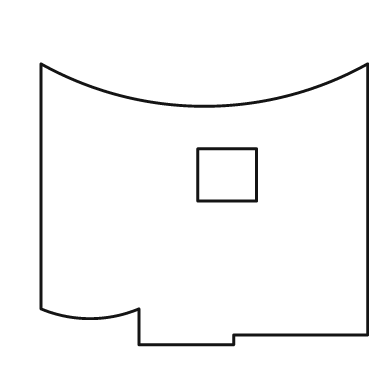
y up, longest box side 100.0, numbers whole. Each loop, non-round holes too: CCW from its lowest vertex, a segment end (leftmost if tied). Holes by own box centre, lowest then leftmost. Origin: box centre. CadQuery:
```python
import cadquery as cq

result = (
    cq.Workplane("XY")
    .moveTo(-20.0, -43.0)
    .lineTo(9.0, -43.0)
    .lineTo(9.0, -40.0)
    .lineTo(50.0, -40.0)
    .lineTo(50.0, 43.0)
    .threePointArc((0.0, 30.0), (-50.0, 43.0))
    .lineTo(-50.0, -32.0)
    .threePointArc((-35.0, -35.0), (-20.0, -32.0))
    .close()
    .moveTo(-2.0, 1.0)
    .lineTo(16.0, 1.0)
    .lineTo(16.0, 17.0)
    .lineTo(-2.0, 17.0)
    .close()
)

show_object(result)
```